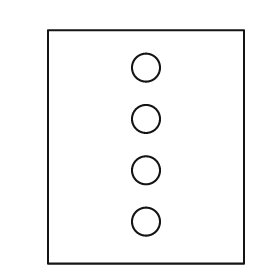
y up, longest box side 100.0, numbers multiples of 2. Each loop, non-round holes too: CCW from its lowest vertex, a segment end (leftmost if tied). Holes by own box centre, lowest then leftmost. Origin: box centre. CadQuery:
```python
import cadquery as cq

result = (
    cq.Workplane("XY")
    .moveTo(-42.0, -50.0)
    .lineTo(42.0, -50.0)
    .lineTo(42.0, 50.0)
    .lineTo(-42.0, 50.0)
    .close()
    .moveTo(0.0, -32.0)
    .circle(6.0)
    .moveTo(0.0, -10.0)
    .circle(6.0)
    .moveTo(0.0, 12.0)
    .circle(6.0)
    .moveTo(0.0, 34.0)
    .circle(6.0)
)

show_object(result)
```